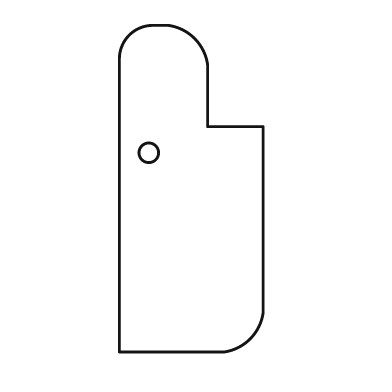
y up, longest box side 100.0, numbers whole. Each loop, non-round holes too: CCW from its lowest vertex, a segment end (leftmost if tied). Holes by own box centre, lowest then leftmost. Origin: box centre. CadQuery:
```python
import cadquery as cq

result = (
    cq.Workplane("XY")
    .moveTo(-22.0, -50.0)
    .lineTo(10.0, -50.0)
    .threePointArc((18.0, -46.0), (22.0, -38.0))
    .lineTo(22.0, 19.0)
    .lineTo(5.0, 19.0)
    .lineTo(5.0, 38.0)
    .threePointArc((1.0, 46.0), (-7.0, 50.0))
    .lineTo(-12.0, 50.0)
    .threePointArc((-19.0, 47.0), (-22.0, 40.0))
    .close()
    .moveTo(-13.0, 11.0)
    .circle(3.0)
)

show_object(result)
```